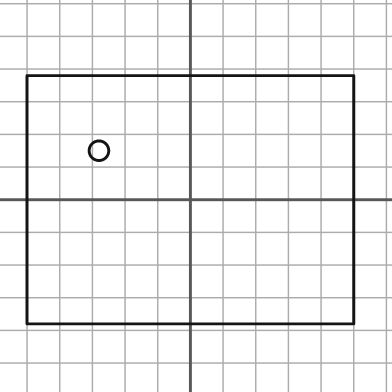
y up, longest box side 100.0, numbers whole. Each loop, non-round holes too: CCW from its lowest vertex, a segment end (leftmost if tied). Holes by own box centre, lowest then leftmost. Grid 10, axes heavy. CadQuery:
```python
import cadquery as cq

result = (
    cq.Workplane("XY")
    .moveTo(-50.0, -38.0)
    .lineTo(50.0, -38.0)
    .lineTo(50.0, 38.0)
    .lineTo(-50.0, 38.0)
    .close()
    .moveTo(-28.0, 15.0)
    .circle(3.0)
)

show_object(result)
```